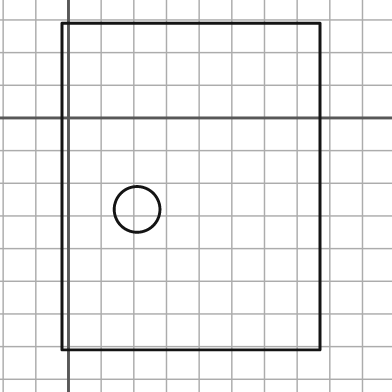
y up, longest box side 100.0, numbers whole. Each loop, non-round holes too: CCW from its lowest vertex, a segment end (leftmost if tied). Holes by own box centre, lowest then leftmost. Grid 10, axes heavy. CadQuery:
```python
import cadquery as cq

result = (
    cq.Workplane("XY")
    .moveTo(-2.0, -71.0)
    .lineTo(77.0, -71.0)
    .lineTo(77.0, 29.0)
    .lineTo(-2.0, 29.0)
    .close()
    .moveTo(21.0, -28.0)
    .circle(7.0)
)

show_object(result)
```